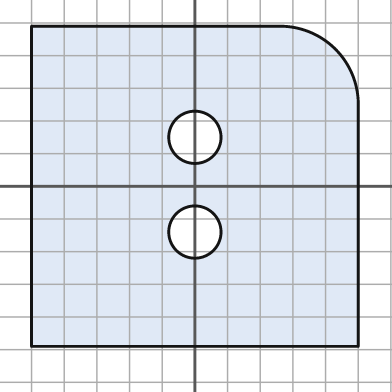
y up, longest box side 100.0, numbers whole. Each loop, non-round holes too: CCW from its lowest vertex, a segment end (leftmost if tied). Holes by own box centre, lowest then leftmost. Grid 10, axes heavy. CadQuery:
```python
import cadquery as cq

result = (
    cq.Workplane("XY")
    .moveTo(-50.0, -49.0)
    .lineTo(50.0, -49.0)
    .lineTo(50.0, 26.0)
    .threePointArc((43.0, 42.0), (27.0, 49.0))
    .lineTo(-50.0, 49.0)
    .close()
    .moveTo(0.0, -14.0)
    .circle(8.0)
    .moveTo(0.0, 15.0)
    .circle(8.0)
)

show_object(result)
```